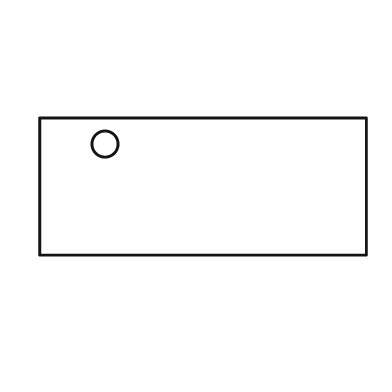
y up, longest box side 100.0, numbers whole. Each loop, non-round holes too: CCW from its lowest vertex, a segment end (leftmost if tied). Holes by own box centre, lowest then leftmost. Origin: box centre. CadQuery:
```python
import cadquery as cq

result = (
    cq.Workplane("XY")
    .moveTo(-50.0, -21.0)
    .lineTo(50.0, -21.0)
    .lineTo(50.0, 21.0)
    .lineTo(-50.0, 21.0)
    .close()
    .moveTo(-30.0, 13.0)
    .circle(4.0)
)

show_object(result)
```